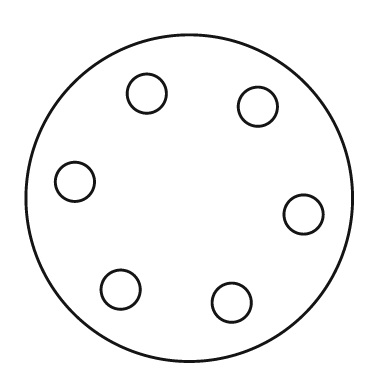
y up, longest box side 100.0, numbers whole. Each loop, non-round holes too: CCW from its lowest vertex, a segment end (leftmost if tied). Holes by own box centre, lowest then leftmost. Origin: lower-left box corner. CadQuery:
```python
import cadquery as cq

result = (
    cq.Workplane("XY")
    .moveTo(50.0, 50.0)
    .circle(50.0)
    .moveTo(63.0, 18.0)
    .circle(6.0)
    .moveTo(29.0, 22.0)
    .circle(6.0)
    .moveTo(85.0, 45.0)
    .circle(6.0)
    .moveTo(15.0, 55.0)
    .circle(6.0)
    .moveTo(71.0, 78.0)
    .circle(6.0)
    .moveTo(37.0, 82.0)
    .circle(6.0)
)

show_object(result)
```